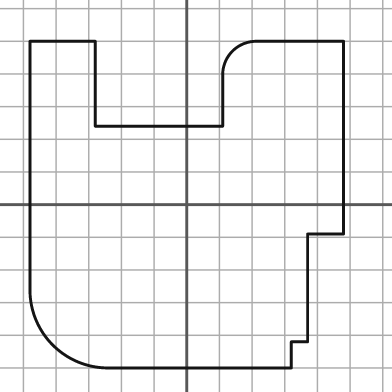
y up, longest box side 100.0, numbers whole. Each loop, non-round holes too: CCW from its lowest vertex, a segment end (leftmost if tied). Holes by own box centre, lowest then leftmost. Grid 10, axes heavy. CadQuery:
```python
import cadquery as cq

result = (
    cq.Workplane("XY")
    .moveTo(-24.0, -50.0)
    .lineTo(32.0, -50.0)
    .lineTo(32.0, -42.0)
    .lineTo(37.0, -42.0)
    .lineTo(37.0, -9.0)
    .lineTo(48.0, -9.0)
    .lineTo(48.0, 50.0)
    .lineTo(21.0, 50.0)
    .threePointArc((14.0, 47.0), (11.0, 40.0))
    .lineTo(11.0, 24.0)
    .lineTo(-28.0, 24.0)
    .lineTo(-28.0, 50.0)
    .lineTo(-48.0, 50.0)
    .lineTo(-48.0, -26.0)
    .threePointArc((-41.0, -43.0), (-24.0, -50.0))
    .close()
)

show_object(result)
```